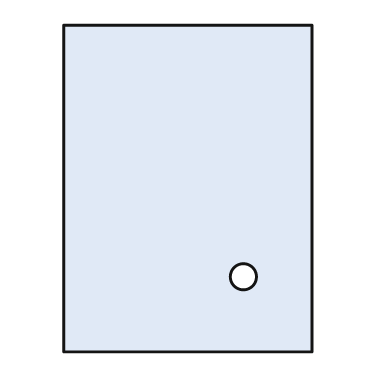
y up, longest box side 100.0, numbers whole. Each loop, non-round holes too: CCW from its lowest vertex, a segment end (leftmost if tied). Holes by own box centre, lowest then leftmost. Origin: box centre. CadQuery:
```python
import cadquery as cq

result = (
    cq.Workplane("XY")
    .moveTo(-38.0, -50.0)
    .lineTo(38.0, -50.0)
    .lineTo(38.0, 50.0)
    .lineTo(-38.0, 50.0)
    .close()
    .moveTo(17.0, -27.0)
    .circle(4.0)
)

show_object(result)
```